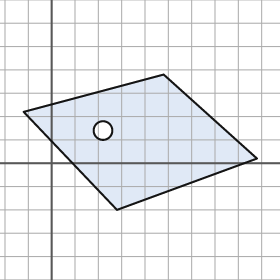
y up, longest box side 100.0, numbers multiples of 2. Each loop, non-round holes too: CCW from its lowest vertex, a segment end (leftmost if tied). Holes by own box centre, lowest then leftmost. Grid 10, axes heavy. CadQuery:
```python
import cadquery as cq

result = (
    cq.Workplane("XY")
    .moveTo(28.0, -20.0)
    .lineTo(88.0, 2.0)
    .lineTo(48.0, 38.0)
    .lineTo(-12.0, 22.0)
    .close()
    .moveTo(22.0, 14.0)
    .circle(4.0)
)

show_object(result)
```